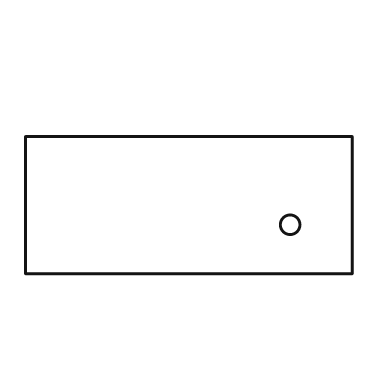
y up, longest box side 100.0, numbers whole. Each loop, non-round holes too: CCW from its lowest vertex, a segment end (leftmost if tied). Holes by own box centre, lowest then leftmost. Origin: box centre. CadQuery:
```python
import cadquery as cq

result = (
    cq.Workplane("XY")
    .moveTo(-50.0, -21.0)
    .lineTo(50.0, -21.0)
    .lineTo(50.0, 21.0)
    .lineTo(-50.0, 21.0)
    .close()
    .moveTo(31.0, -6.0)
    .circle(3.0)
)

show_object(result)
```